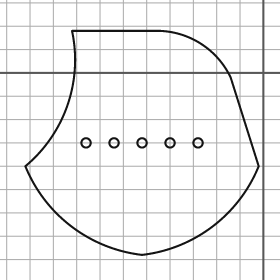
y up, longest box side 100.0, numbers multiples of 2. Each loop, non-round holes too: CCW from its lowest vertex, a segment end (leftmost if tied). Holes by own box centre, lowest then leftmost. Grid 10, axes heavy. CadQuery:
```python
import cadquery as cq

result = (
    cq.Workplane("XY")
    .moveTo(-52.0, -78.0)
    .threePointArc((-22.0, -66.0), (-2.0, -40.0))
    .lineTo(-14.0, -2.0)
    .threePointArc((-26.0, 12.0), (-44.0, 18.0))
    .lineTo(-82.0, 18.0)
    .threePointArc((-84.0, -14.0), (-102.0, -40.0))
    .threePointArc((-82.0, -66.0), (-52.0, -78.0))
    .close()
    .moveTo(-76.0, -30.0)
    .circle(2.0)
    .moveTo(-64.0, -30.0)
    .circle(2.0)
    .moveTo(-52.0, -30.0)
    .circle(2.0)
    .moveTo(-40.0, -30.0)
    .circle(2.0)
    .moveTo(-28.0, -30.0)
    .circle(2.0)
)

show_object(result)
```